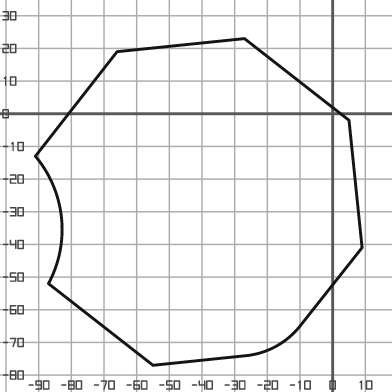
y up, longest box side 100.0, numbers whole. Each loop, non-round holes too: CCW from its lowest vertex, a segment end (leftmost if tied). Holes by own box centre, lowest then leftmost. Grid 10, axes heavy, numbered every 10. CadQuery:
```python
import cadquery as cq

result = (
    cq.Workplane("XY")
    .moveTo(-55.0, -77.0)
    .lineTo(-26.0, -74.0)
    .threePointArc((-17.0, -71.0), (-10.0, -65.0))
    .lineTo(9.0, -41.0)
    .lineTo(5.0, -2.0)
    .lineTo(-27.0, 23.0)
    .lineTo(-66.0, 19.0)
    .lineTo(-91.0, -13.0)
    .threePointArc((-83.0, -32.0), (-87.0, -52.0))
    .close()
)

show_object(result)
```